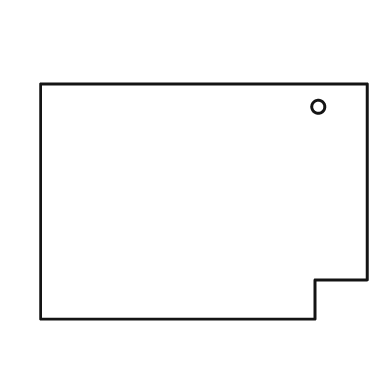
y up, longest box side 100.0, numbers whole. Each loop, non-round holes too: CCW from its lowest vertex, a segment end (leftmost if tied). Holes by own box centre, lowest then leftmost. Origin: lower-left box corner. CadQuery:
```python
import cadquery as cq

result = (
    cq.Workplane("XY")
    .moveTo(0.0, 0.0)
    .lineTo(84.0, 0.0)
    .lineTo(84.0, 12.0)
    .lineTo(100.0, 12.0)
    .lineTo(100.0, 72.0)
    .lineTo(0.0, 72.0)
    .close()
    .moveTo(85.0, 65.0)
    .circle(2.0)
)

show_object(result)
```